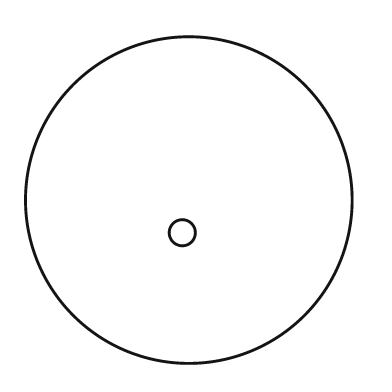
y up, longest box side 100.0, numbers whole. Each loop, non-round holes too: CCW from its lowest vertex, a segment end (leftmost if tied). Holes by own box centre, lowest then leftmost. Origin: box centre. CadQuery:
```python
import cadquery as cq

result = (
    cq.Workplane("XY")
    .moveTo(0.0, 0.0)
    .circle(50.0)
    .moveTo(-2.0, -10.0)
    .circle(4.0)
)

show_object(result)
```